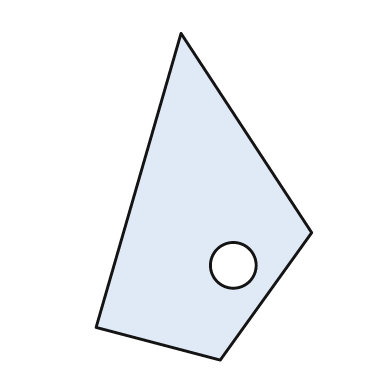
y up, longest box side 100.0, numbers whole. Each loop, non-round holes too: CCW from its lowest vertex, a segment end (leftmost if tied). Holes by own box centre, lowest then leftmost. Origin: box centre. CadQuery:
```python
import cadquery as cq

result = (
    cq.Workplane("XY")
    .moveTo(5.0, -50.0)
    .lineTo(33.0, -11.0)
    .lineTo(-7.0, 50.0)
    .lineTo(-33.0, -40.0)
    .close()
    .moveTo(9.0, -21.0)
    .circle(7.0)
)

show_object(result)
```